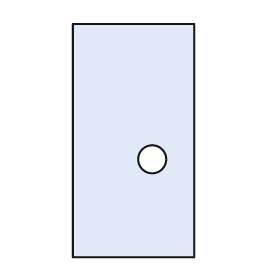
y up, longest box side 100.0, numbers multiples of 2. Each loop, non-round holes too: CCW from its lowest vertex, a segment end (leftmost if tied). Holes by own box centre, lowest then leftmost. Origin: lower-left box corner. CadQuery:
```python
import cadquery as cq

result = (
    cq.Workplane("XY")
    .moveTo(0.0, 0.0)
    .lineTo(52.0, 0.0)
    .lineTo(52.0, 100.0)
    .lineTo(0.0, 100.0)
    .close()
    .moveTo(34.0, 42.0)
    .circle(6.0)
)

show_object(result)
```